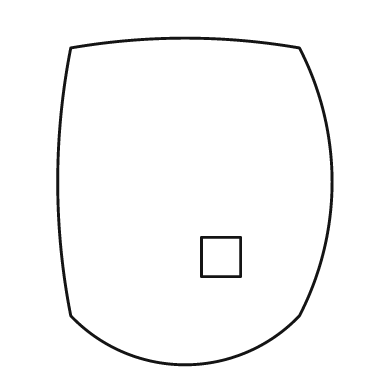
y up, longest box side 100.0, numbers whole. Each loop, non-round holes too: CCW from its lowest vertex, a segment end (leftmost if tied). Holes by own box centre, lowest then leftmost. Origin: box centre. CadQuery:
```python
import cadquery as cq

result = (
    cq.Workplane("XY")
    .moveTo(-38.0, -35.0)
    .threePointArc((-3.0, -50.0), (32.0, -35.0))
    .threePointArc((42.0, 6.0), (32.0, 47.0))
    .threePointArc((-3.0, 50.0), (-38.0, 47.0))
    .threePointArc((-42.0, 6.0), (-38.0, -35.0))
    .close()
    .moveTo(2.0, -23.0)
    .lineTo(14.0, -23.0)
    .lineTo(14.0, -11.0)
    .lineTo(2.0, -11.0)
    .close()
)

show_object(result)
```